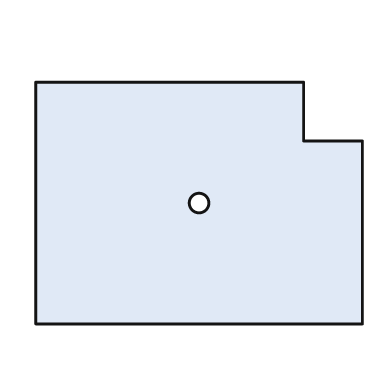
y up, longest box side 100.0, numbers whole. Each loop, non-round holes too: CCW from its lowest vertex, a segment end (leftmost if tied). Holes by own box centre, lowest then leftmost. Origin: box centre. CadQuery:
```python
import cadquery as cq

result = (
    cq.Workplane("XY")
    .moveTo(-50.0, -37.0)
    .lineTo(50.0, -37.0)
    .lineTo(50.0, 19.0)
    .lineTo(32.0, 19.0)
    .lineTo(32.0, 37.0)
    .lineTo(-50.0, 37.0)
    .close()
    .moveTo(0.0, 0.0)
    .circle(3.0)
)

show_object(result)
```